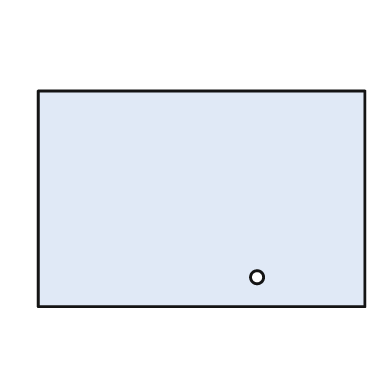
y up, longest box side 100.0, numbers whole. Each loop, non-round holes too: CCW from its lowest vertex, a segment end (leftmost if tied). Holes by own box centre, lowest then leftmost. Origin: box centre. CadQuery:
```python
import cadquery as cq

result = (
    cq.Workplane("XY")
    .moveTo(-50.0, -33.0)
    .lineTo(50.0, -33.0)
    .lineTo(50.0, 33.0)
    .lineTo(-50.0, 33.0)
    .close()
    .moveTo(17.0, -24.0)
    .circle(2.0)
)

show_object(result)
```